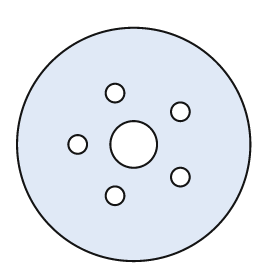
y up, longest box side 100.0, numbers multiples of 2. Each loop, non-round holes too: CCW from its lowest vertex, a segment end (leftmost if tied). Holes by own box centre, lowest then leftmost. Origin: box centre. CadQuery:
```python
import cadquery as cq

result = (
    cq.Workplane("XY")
    .moveTo(0.0, 0.0)
    .circle(50.0)
    .moveTo(-8.0, -22.0)
    .circle(4.0)
    .moveTo(20.0, -14.0)
    .circle(4.0)
    .moveTo(-24.0, 0.0)
    .circle(4.0)
    .moveTo(0.0, 0.0)
    .circle(10.0)
    .moveTo(20.0, 14.0)
    .circle(4.0)
    .moveTo(-8.0, 22.0)
    .circle(4.0)
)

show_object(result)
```